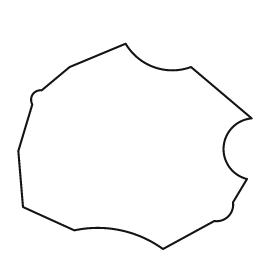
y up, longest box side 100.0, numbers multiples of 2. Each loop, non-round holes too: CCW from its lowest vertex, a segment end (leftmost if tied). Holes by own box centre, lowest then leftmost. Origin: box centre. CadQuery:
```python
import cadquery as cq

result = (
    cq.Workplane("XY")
    .moveTo(12.0, -44.0)
    .lineTo(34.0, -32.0)
    .threePointArc((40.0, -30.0), (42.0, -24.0))
    .lineTo(48.0, -14.0)
    .threePointArc((38.0, 0.0), (50.0, 12.0))
    .lineTo(24.0, 34.0)
    .threePointArc((8.0, 34.0), (-4.0, 44.0))
    .lineTo(-28.0, 34.0)
    .lineTo(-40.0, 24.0)
    .threePointArc((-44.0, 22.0), (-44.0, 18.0))
    .lineTo(-50.0, -2.0)
    .lineTo(-48.0, -26.0)
    .lineTo(-26.0, -36.0)
    .threePointArc((-6.0, -36.0), (12.0, -44.0))
    .close()
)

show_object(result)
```